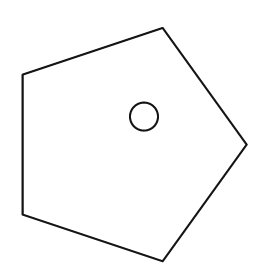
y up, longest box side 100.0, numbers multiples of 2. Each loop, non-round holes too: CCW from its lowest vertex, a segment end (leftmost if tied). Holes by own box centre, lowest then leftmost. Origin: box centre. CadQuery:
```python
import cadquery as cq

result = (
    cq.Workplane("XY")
    .moveTo(12.0, -50.0)
    .lineTo(48.0, 0.0)
    .lineTo(12.0, 50.0)
    .lineTo(-48.0, 30.0)
    .lineTo(-48.0, -30.0)
    .close()
    .moveTo(4.0, 12.0)
    .circle(6.0)
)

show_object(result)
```